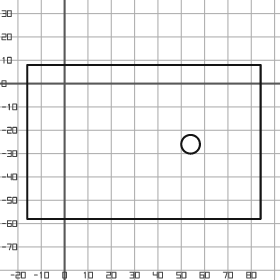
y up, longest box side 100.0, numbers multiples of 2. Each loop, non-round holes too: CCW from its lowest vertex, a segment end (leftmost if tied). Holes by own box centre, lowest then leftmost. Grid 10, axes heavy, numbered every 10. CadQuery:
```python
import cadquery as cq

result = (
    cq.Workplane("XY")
    .moveTo(-16.0, -58.0)
    .lineTo(84.0, -58.0)
    .lineTo(84.0, 8.0)
    .lineTo(-16.0, 8.0)
    .close()
    .moveTo(54.0, -26.0)
    .circle(4.0)
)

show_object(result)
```